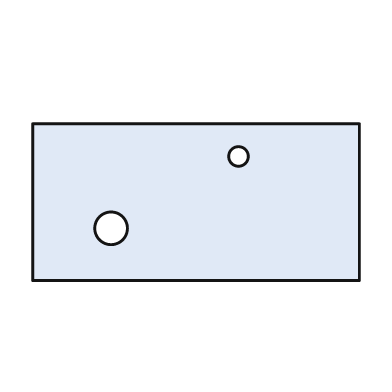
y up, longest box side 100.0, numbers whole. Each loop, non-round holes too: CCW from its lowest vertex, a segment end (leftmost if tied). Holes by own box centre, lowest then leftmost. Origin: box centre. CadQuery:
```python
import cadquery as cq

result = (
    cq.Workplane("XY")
    .moveTo(-50.0, -24.0)
    .lineTo(50.0, -24.0)
    .lineTo(50.0, 24.0)
    .lineTo(-50.0, 24.0)
    .close()
    .moveTo(-26.0, -8.0)
    .circle(5.0)
    .moveTo(13.0, 14.0)
    .circle(3.0)
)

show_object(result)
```